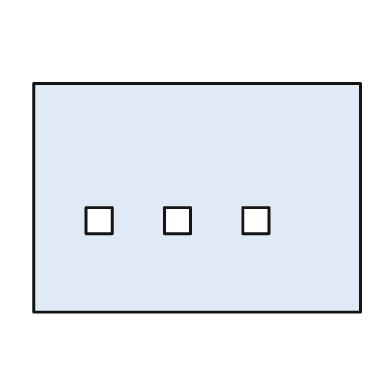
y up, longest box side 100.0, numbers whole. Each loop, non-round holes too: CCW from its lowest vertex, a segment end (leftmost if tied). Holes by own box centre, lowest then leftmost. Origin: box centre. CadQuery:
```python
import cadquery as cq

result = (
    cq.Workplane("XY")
    .moveTo(-50.0, -35.0)
    .lineTo(50.0, -35.0)
    .lineTo(50.0, 35.0)
    .lineTo(-50.0, 35.0)
    .close()
    .moveTo(-34.0, -11.0)
    .lineTo(-26.0, -11.0)
    .lineTo(-26.0, -3.0)
    .lineTo(-34.0, -3.0)
    .close()
    .moveTo(-10.0, -11.0)
    .lineTo(-2.0, -11.0)
    .lineTo(-2.0, -3.0)
    .lineTo(-10.0, -3.0)
    .close()
    .moveTo(14.0, -11.0)
    .lineTo(22.0, -11.0)
    .lineTo(22.0, -3.0)
    .lineTo(14.0, -3.0)
    .close()
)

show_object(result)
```